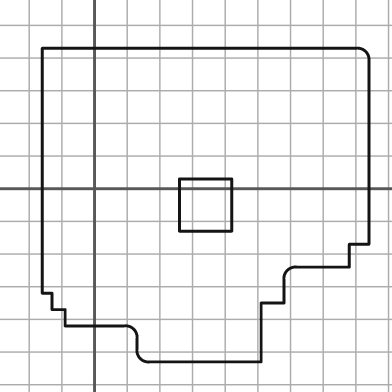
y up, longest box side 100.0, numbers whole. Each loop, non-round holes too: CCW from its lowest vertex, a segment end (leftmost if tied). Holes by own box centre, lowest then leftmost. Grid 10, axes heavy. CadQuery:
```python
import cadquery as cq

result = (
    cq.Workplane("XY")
    .moveTo(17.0, -53.0)
    .lineTo(51.0, -53.0)
    .lineTo(51.0, -35.0)
    .lineTo(58.0, -35.0)
    .lineTo(58.0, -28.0)
    .threePointArc((59.0, -25.0), (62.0, -24.0))
    .lineTo(78.0, -24.0)
    .lineTo(78.0, -17.0)
    .lineTo(84.0, -17.0)
    .lineTo(84.0, 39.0)
    .threePointArc((83.0, 42.0), (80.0, 43.0))
    .lineTo(-16.0, 43.0)
    .lineTo(-16.0, -32.0)
    .lineTo(-13.0, -32.0)
    .lineTo(-13.0, -37.0)
    .lineTo(-9.0, -37.0)
    .lineTo(-9.0, -42.0)
    .lineTo(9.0, -42.0)
    .threePointArc((12.0, -43.0), (13.0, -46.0))
    .lineTo(13.0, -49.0)
    .threePointArc((14.0, -52.0), (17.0, -53.0))
    .close()
    .moveTo(26.0, -13.0)
    .lineTo(42.0, -13.0)
    .lineTo(42.0, 3.0)
    .lineTo(26.0, 3.0)
    .close()
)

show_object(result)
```